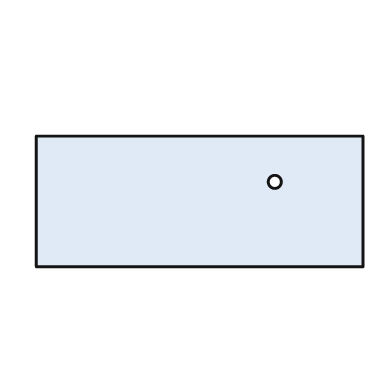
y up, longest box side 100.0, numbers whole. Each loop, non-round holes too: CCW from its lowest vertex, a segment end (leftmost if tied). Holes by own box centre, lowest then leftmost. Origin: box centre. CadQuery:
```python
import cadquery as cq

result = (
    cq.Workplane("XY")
    .moveTo(-50.0, -20.0)
    .lineTo(50.0, -20.0)
    .lineTo(50.0, 20.0)
    .lineTo(-50.0, 20.0)
    .close()
    .moveTo(23.0, 6.0)
    .circle(2.0)
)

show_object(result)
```